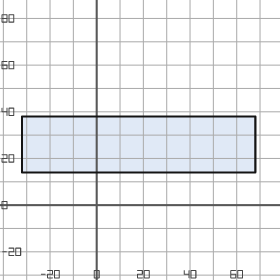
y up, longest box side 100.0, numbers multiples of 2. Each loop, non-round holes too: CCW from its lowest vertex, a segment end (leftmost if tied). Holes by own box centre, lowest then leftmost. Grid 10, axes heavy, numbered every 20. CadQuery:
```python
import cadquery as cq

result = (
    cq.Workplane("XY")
    .moveTo(-32.0, 14.0)
    .lineTo(68.0, 14.0)
    .lineTo(68.0, 38.0)
    .lineTo(-32.0, 38.0)
    .close()
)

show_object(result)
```